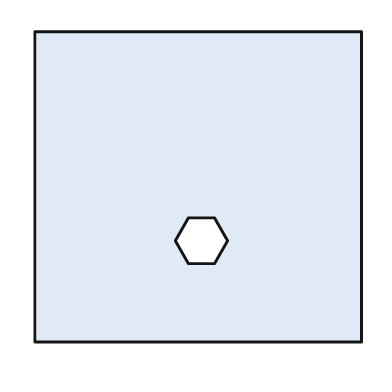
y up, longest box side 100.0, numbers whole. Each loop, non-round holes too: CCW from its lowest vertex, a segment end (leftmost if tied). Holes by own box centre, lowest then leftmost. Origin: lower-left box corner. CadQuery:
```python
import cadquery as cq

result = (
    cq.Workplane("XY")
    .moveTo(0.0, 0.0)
    .lineTo(100.0, 0.0)
    .lineTo(100.0, 95.0)
    .lineTo(0.0, 95.0)
    .close()
    .moveTo(47.0, 24.0)
    .lineTo(55.0, 24.0)
    .lineTo(59.0, 31.0)
    .lineTo(55.0, 38.0)
    .lineTo(47.0, 38.0)
    .lineTo(43.0, 31.0)
    .close()
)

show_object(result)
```